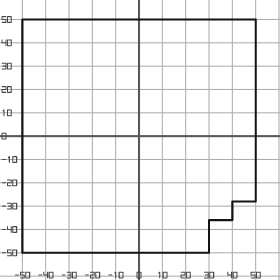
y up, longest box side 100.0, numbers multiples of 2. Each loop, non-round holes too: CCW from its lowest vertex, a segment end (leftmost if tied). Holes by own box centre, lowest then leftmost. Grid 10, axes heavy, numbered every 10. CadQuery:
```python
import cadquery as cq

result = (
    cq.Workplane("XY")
    .moveTo(-50.0, -50.0)
    .lineTo(30.0, -50.0)
    .lineTo(30.0, -36.0)
    .lineTo(40.0, -36.0)
    .lineTo(40.0, -28.0)
    .lineTo(50.0, -28.0)
    .lineTo(50.0, 50.0)
    .lineTo(-50.0, 50.0)
    .close()
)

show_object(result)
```